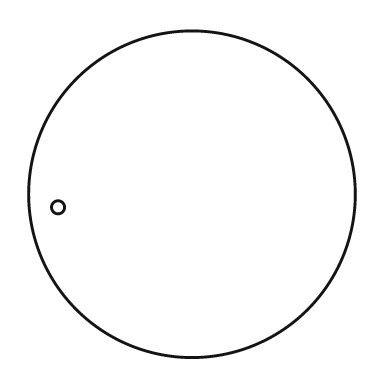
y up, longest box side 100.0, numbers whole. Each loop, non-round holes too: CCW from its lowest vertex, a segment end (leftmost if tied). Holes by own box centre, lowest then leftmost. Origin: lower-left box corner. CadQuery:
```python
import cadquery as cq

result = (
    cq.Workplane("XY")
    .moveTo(50.0, 50.0)
    .circle(50.0)
    .moveTo(9.0, 46.0)
    .circle(2.0)
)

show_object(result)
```